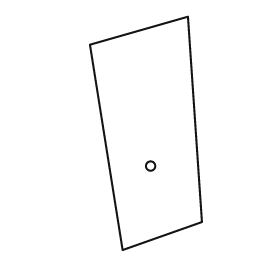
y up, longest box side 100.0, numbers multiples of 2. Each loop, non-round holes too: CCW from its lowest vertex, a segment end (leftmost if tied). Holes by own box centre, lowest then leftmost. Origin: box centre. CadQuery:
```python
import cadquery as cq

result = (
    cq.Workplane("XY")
    .moveTo(-10.0, -50.0)
    .lineTo(24.0, -38.0)
    .lineTo(18.0, 50.0)
    .lineTo(-24.0, 38.0)
    .close()
    .moveTo(2.0, -14.0)
    .circle(2.0)
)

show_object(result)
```